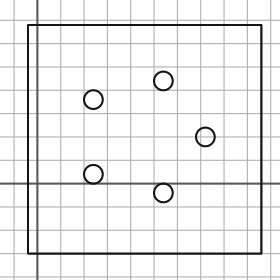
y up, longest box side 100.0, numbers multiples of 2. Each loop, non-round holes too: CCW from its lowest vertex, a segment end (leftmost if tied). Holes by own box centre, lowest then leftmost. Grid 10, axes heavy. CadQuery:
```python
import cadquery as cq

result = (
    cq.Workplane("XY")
    .moveTo(-4.0, -30.0)
    .lineTo(96.0, -30.0)
    .lineTo(96.0, 68.0)
    .lineTo(-4.0, 68.0)
    .close()
    .moveTo(54.0, -4.0)
    .circle(4.0)
    .moveTo(24.0, 4.0)
    .circle(4.0)
    .moveTo(72.0, 20.0)
    .circle(4.0)
    .moveTo(24.0, 36.0)
    .circle(4.0)
    .moveTo(54.0, 44.0)
    .circle(4.0)
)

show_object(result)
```